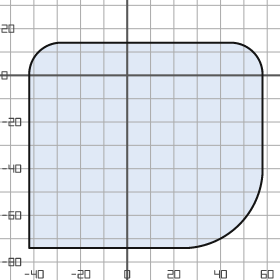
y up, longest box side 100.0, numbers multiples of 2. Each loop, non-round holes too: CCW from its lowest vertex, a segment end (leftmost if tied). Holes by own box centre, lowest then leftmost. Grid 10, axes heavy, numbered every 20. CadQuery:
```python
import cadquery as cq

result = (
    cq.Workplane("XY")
    .moveTo(-42.0, -74.0)
    .lineTo(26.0, -74.0)
    .threePointArc((48.0, -64.0), (58.0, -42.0))
    .lineTo(58.0, 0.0)
    .threePointArc((54.0, 10.0), (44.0, 14.0))
    .lineTo(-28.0, 14.0)
    .threePointArc((-38.0, 10.0), (-42.0, 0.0))
    .close()
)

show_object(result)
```